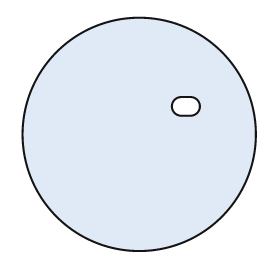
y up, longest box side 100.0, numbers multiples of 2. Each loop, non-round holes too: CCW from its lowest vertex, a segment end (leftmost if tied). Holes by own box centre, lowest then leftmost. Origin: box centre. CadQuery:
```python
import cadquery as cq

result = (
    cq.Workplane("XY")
    .moveTo(0.0, 0.0)
    .circle(50.0)
    .moveTo(18.0, 8.0)
    .lineTo(22.0, 8.0)
    .threePointArc((26.0, 12.0), (22.0, 16.0))
    .lineTo(18.0, 16.0)
    .threePointArc((14.0, 12.0), (18.0, 8.0))
    .close()
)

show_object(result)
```